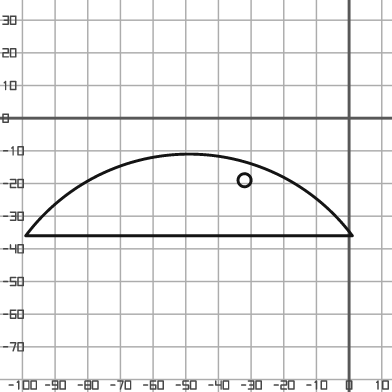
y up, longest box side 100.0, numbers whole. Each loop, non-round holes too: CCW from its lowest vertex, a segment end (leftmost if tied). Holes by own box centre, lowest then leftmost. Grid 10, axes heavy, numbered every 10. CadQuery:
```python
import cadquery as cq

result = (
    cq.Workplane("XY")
    .moveTo(-99.0, -36.0)
    .lineTo(1.0, -36.0)
    .threePointArc((-49.0, -11.0), (-99.0, -36.0))
    .close()
    .moveTo(-32.0, -19.0)
    .circle(2.0)
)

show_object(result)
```